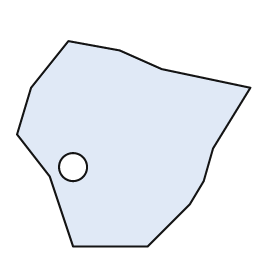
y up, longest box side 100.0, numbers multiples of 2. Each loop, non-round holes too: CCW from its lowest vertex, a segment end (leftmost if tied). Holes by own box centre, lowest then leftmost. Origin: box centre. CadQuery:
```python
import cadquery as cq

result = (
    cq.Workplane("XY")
    .moveTo(-26.0, -44.0)
    .lineTo(6.0, -44.0)
    .lineTo(24.0, -26.0)
    .lineTo(30.0, -16.0)
    .lineTo(34.0, -2.0)
    .lineTo(50.0, 24.0)
    .lineTo(12.0, 32.0)
    .lineTo(-6.0, 40.0)
    .lineTo(-28.0, 44.0)
    .lineTo(-44.0, 24.0)
    .lineTo(-50.0, 4.0)
    .lineTo(-36.0, -14.0)
    .close()
    .moveTo(-26.0, -10.0)
    .circle(6.0)
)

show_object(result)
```